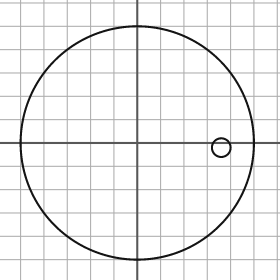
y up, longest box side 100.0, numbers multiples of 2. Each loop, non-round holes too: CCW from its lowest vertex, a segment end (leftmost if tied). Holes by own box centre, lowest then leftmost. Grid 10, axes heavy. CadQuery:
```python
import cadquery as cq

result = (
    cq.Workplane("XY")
    .moveTo(0.0, 0.0)
    .circle(50.0)
    .moveTo(36.0, -2.0)
    .circle(4.0)
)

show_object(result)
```